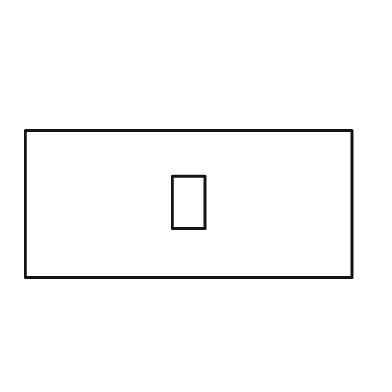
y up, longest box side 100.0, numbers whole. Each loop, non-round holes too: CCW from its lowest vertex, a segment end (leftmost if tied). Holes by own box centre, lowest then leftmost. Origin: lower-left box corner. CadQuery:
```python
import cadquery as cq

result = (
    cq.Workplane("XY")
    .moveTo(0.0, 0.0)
    .lineTo(100.0, 0.0)
    .lineTo(100.0, 45.0)
    .lineTo(0.0, 45.0)
    .close()
    .moveTo(45.0, 15.0)
    .lineTo(55.0, 15.0)
    .lineTo(55.0, 31.0)
    .lineTo(45.0, 31.0)
    .close()
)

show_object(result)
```